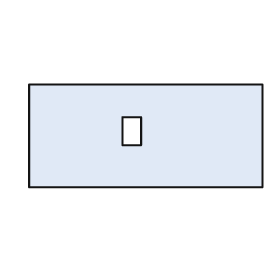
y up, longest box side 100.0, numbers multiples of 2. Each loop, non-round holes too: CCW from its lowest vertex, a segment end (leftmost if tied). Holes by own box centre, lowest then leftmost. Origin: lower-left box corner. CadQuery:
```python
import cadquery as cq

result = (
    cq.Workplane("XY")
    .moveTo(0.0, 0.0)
    .lineTo(100.0, 0.0)
    .lineTo(100.0, 44.0)
    .lineTo(0.0, 44.0)
    .close()
    .moveTo(40.0, 18.0)
    .lineTo(48.0, 18.0)
    .lineTo(48.0, 30.0)
    .lineTo(40.0, 30.0)
    .close()
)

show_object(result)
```